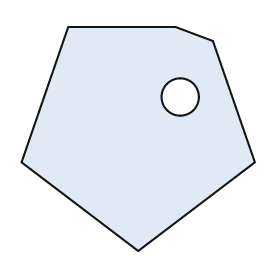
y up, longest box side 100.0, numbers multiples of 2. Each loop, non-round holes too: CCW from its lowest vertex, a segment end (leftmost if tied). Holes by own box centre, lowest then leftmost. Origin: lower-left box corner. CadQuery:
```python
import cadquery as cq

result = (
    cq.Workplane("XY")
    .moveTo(50.0, 0.0)
    .lineTo(100.0, 38.0)
    .lineTo(82.0, 90.0)
    .lineTo(66.0, 96.0)
    .lineTo(20.0, 96.0)
    .lineTo(0.0, 38.0)
    .close()
    .moveTo(68.0, 66.0)
    .circle(8.0)
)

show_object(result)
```